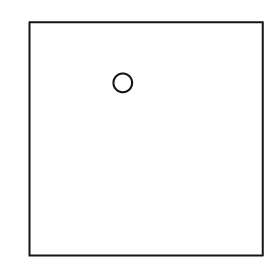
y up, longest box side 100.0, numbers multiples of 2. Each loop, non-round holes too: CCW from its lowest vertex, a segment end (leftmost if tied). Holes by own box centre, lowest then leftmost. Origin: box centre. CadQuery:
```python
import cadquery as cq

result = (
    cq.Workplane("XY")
    .moveTo(-50.0, -50.0)
    .lineTo(50.0, -50.0)
    .lineTo(50.0, 50.0)
    .lineTo(-50.0, 50.0)
    .close()
    .moveTo(-10.0, 24.0)
    .circle(4.0)
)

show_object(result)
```